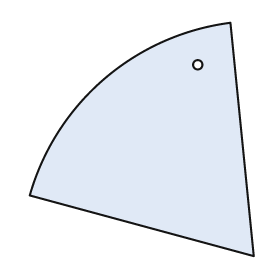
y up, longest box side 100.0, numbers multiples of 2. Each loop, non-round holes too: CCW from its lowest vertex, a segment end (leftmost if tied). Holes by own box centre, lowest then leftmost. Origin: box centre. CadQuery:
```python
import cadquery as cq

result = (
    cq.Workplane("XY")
    .moveTo(48.0, -50.0)
    .lineTo(38.0, 50.0)
    .threePointArc((-16.0, 26.0), (-48.0, -24.0))
    .close()
    .moveTo(24.0, 32.0)
    .circle(2.0)
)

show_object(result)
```